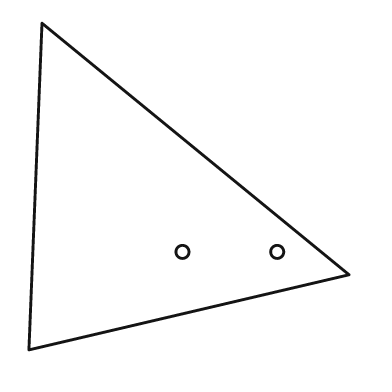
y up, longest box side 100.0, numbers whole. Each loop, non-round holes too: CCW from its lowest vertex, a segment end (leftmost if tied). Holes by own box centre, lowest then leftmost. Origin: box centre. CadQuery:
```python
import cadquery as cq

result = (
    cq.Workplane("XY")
    .moveTo(-49.0, -50.0)
    .lineTo(49.0, -27.0)
    .lineTo(-45.0, 50.0)
    .close()
    .moveTo(-2.0, -20.0)
    .circle(2.0)
    .moveTo(27.0, -20.0)
    .circle(2.0)
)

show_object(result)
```